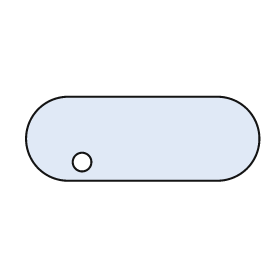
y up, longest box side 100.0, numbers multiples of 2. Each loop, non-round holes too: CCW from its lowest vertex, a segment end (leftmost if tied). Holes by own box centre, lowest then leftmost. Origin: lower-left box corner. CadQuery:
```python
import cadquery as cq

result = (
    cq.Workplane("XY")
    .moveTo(18.0, 0.0)
    .lineTo(82.0, 0.0)
    .threePointArc((100.0, 18.0), (82.0, 36.0))
    .lineTo(18.0, 36.0)
    .threePointArc((0.0, 18.0), (18.0, 0.0))
    .close()
    .moveTo(24.0, 8.0)
    .circle(4.0)
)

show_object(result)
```